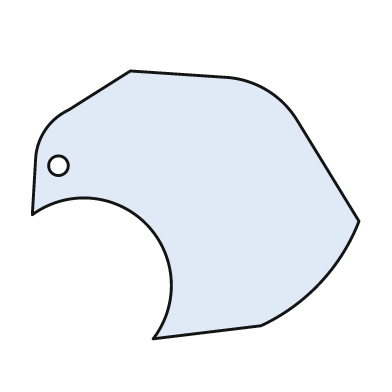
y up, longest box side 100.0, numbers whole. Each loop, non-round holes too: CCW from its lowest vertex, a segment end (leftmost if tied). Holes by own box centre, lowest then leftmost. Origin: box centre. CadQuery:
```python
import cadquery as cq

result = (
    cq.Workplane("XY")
    .moveTo(-13.0, -41.0)
    .lineTo(20.0, -37.0)
    .threePointArc((38.0, -24.0), (50.0, -5.0))
    .lineTo(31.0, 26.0)
    .threePointArc((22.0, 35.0), (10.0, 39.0))
    .lineTo(-20.0, 41.0)
    .lineTo(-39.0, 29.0)
    .threePointArc((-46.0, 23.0), (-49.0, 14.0))
    .lineTo(-50.0, -3.0)
    .threePointArc((-15.0, -6.0), (-13.0, -41.0))
    .close()
    .moveTo(-42.0, 12.0)
    .circle(3.0)
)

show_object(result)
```